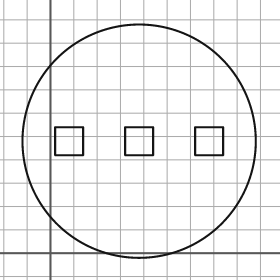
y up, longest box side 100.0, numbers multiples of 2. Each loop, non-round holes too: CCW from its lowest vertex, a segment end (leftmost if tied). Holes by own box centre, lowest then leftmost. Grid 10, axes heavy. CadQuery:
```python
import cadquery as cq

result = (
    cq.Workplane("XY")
    .moveTo(38.0, 48.0)
    .circle(50.0)
    .moveTo(2.0, 42.0)
    .lineTo(14.0, 42.0)
    .lineTo(14.0, 54.0)
    .lineTo(2.0, 54.0)
    .close()
    .moveTo(32.0, 42.0)
    .lineTo(44.0, 42.0)
    .lineTo(44.0, 54.0)
    .lineTo(32.0, 54.0)
    .close()
    .moveTo(62.0, 42.0)
    .lineTo(74.0, 42.0)
    .lineTo(74.0, 54.0)
    .lineTo(62.0, 54.0)
    .close()
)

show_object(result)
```